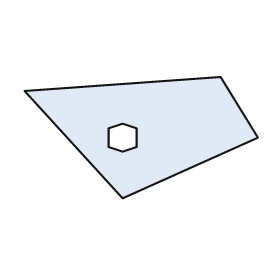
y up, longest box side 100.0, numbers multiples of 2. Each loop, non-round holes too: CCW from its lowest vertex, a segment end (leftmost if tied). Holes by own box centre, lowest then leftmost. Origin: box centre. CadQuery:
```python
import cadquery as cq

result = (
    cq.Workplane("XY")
    .moveTo(-8.0, -26.0)
    .lineTo(50.0, 0.0)
    .lineTo(34.0, 26.0)
    .lineTo(-50.0, 20.0)
    .close()
    .moveTo(-8.0, -6.0)
    .lineTo(-2.0, -4.0)
    .lineTo(-2.0, 4.0)
    .lineTo(-8.0, 6.0)
    .lineTo(-14.0, 4.0)
    .lineTo(-14.0, -4.0)
    .close()
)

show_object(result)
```